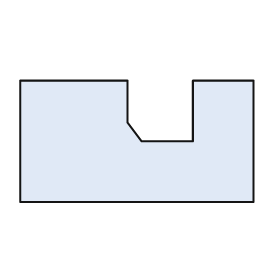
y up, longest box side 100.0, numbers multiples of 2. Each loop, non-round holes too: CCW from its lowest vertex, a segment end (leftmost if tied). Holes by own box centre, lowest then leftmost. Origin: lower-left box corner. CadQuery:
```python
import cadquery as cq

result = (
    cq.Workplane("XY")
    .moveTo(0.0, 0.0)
    .lineTo(100.0, 0.0)
    .lineTo(100.0, 52.0)
    .lineTo(74.0, 52.0)
    .lineTo(74.0, 26.0)
    .lineTo(52.0, 26.0)
    .lineTo(46.0, 34.0)
    .lineTo(46.0, 52.0)
    .lineTo(0.0, 52.0)
    .close()
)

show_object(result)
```